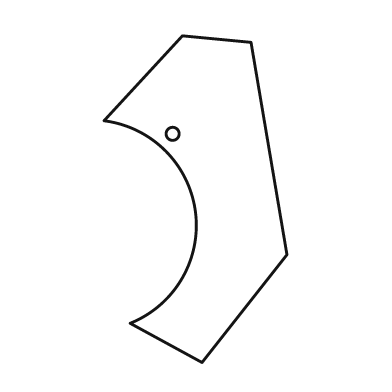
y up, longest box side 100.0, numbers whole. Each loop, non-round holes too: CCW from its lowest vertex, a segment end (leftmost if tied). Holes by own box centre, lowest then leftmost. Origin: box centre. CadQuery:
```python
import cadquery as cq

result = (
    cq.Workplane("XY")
    .moveTo(2.0, -50.0)
    .lineTo(28.0, -17.0)
    .lineTo(17.0, 48.0)
    .lineTo(-4.0, 50.0)
    .lineTo(-28.0, 24.0)
    .threePointArc((0.0, -4.0), (-20.0, -38.0))
    .close()
    .moveTo(-7.0, 20.0)
    .circle(2.0)
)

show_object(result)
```